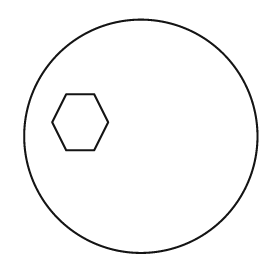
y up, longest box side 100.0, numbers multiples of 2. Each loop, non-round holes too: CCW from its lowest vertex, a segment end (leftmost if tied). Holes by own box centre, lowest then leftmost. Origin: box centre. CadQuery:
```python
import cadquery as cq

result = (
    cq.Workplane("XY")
    .moveTo(0.0, 0.0)
    .circle(50.0)
    .moveTo(-32.0, -6.0)
    .lineTo(-20.0, -6.0)
    .lineTo(-14.0, 6.0)
    .lineTo(-20.0, 18.0)
    .lineTo(-32.0, 18.0)
    .lineTo(-38.0, 6.0)
    .close()
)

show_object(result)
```